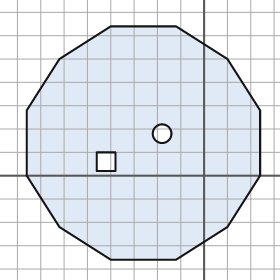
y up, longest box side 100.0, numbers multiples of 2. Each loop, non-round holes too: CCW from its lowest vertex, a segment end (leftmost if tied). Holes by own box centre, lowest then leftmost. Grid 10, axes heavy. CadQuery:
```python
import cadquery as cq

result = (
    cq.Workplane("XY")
    .moveTo(-40.0, -36.0)
    .lineTo(-12.0, -36.0)
    .lineTo(10.0, -22.0)
    .lineTo(24.0, 0.0)
    .lineTo(24.0, 28.0)
    .lineTo(10.0, 50.0)
    .lineTo(-12.0, 64.0)
    .lineTo(-40.0, 64.0)
    .lineTo(-62.0, 50.0)
    .lineTo(-76.0, 28.0)
    .lineTo(-76.0, 0.0)
    .lineTo(-62.0, -22.0)
    .close()
    .moveTo(-46.0, 2.0)
    .lineTo(-38.0, 2.0)
    .lineTo(-38.0, 10.0)
    .lineTo(-46.0, 10.0)
    .close()
    .moveTo(-18.0, 18.0)
    .circle(4.0)
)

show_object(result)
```